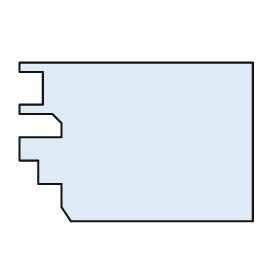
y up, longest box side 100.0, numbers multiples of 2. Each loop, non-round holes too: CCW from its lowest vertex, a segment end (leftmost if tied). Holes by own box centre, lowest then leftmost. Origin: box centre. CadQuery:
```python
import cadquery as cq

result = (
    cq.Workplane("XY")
    .moveTo(-28.0, -34.0)
    .lineTo(50.0, -34.0)
    .lineTo(50.0, 34.0)
    .lineTo(-50.0, 34.0)
    .lineTo(-50.0, 30.0)
    .lineTo(-40.0, 30.0)
    .lineTo(-40.0, 16.0)
    .lineTo(-50.0, 16.0)
    .lineTo(-50.0, 12.0)
    .lineTo(-36.0, 12.0)
    .lineTo(-32.0, 8.0)
    .lineTo(-32.0, 2.0)
    .lineTo(-50.0, 2.0)
    .lineTo(-50.0, -8.0)
    .lineTo(-42.0, -8.0)
    .lineTo(-42.0, -18.0)
    .lineTo(-32.0, -18.0)
    .lineTo(-32.0, -28.0)
    .close()
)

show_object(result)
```